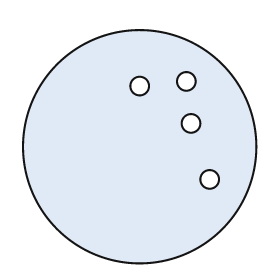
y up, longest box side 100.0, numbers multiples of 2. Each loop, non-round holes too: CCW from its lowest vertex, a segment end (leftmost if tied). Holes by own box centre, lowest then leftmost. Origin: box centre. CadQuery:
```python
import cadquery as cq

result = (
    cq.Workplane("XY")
    .moveTo(0.0, 0.0)
    .circle(50.0)
    .moveTo(30.0, -14.0)
    .circle(4.0)
    .moveTo(22.0, 10.0)
    .circle(4.0)
    .moveTo(0.0, 26.0)
    .circle(4.0)
    .moveTo(20.0, 28.0)
    .circle(4.0)
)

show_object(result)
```